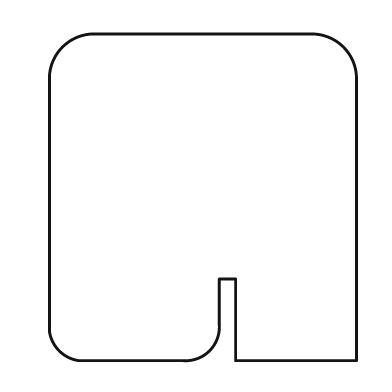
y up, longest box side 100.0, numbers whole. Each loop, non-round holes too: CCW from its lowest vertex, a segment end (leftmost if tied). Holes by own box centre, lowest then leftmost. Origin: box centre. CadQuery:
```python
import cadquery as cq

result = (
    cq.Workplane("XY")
    .moveTo(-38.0, -50.0)
    .lineTo(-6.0, -50.0)
    .threePointArc((2.0, -47.0), (5.0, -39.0))
    .lineTo(5.0, -25.0)
    .lineTo(10.0, -25.0)
    .lineTo(10.0, -50.0)
    .lineTo(47.0, -50.0)
    .lineTo(47.0, 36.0)
    .threePointArc((43.0, 46.0), (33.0, 50.0))
    .lineTo(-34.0, 50.0)
    .threePointArc((-43.0, 46.0), (-47.0, 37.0))
    .lineTo(-47.0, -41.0)
    .threePointArc((-44.0, -47.0), (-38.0, -50.0))
    .close()
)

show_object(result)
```